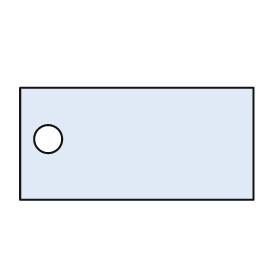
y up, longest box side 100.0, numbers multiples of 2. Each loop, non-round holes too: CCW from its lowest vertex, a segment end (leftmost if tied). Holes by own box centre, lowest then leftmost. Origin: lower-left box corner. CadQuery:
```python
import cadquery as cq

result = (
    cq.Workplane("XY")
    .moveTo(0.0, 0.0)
    .lineTo(100.0, 0.0)
    .lineTo(100.0, 48.0)
    .lineTo(0.0, 48.0)
    .close()
    .moveTo(12.0, 26.0)
    .circle(6.0)
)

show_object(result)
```